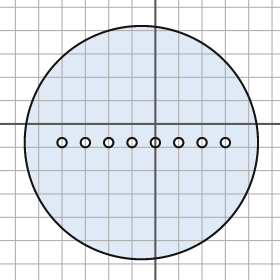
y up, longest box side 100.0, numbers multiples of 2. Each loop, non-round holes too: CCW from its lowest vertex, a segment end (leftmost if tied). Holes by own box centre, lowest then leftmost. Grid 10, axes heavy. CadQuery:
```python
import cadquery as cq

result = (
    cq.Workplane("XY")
    .moveTo(-6.0, -8.0)
    .circle(50.0)
    .moveTo(-40.0, -8.0)
    .circle(2.0)
    .moveTo(-30.0, -8.0)
    .circle(2.0)
    .moveTo(-20.0, -8.0)
    .circle(2.0)
    .moveTo(-10.0, -8.0)
    .circle(2.0)
    .moveTo(0.0, -8.0)
    .circle(2.0)
    .moveTo(10.0, -8.0)
    .circle(2.0)
    .moveTo(20.0, -8.0)
    .circle(2.0)
    .moveTo(30.0, -8.0)
    .circle(2.0)
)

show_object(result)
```